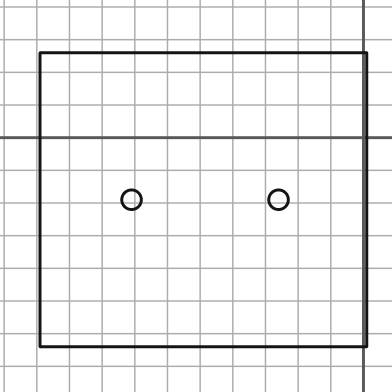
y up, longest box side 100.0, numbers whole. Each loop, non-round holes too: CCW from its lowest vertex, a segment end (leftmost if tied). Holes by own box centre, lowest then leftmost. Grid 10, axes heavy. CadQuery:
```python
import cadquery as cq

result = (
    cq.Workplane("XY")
    .moveTo(-99.0, -64.0)
    .lineTo(1.0, -64.0)
    .lineTo(1.0, 26.0)
    .lineTo(-99.0, 26.0)
    .close()
    .moveTo(-71.0, -19.0)
    .circle(3.0)
    .moveTo(-26.0, -19.0)
    .circle(3.0)
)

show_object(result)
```